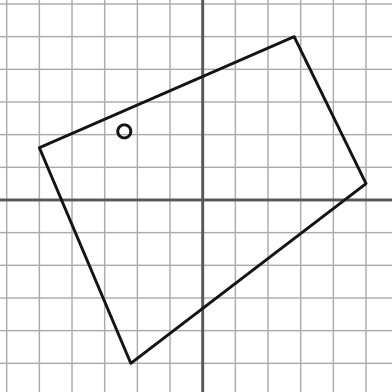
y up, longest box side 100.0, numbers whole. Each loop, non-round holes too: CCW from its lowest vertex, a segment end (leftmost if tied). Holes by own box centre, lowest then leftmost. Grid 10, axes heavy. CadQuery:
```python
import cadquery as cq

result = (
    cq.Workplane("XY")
    .moveTo(-22.0, -50.0)
    .lineTo(50.0, 5.0)
    .lineTo(28.0, 50.0)
    .lineTo(-50.0, 16.0)
    .close()
    .moveTo(-24.0, 21.0)
    .circle(2.0)
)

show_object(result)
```